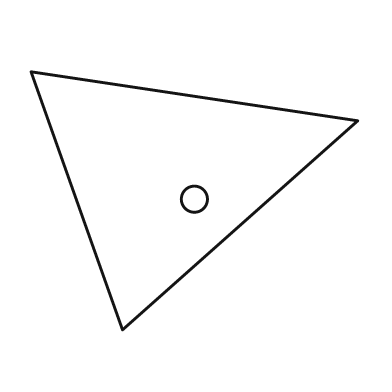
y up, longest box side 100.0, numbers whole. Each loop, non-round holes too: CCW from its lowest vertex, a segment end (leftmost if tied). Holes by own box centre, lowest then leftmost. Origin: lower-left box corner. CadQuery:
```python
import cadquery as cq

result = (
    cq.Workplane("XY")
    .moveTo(28.0, 0.0)
    .lineTo(100.0, 64.0)
    .lineTo(0.0, 79.0)
    .close()
    .moveTo(50.0, 40.0)
    .circle(4.0)
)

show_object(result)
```